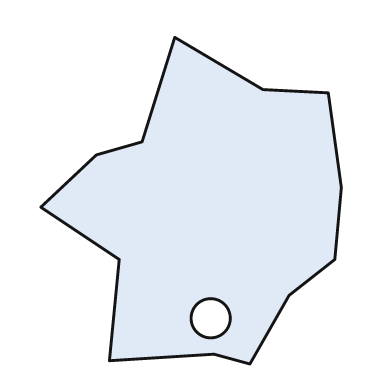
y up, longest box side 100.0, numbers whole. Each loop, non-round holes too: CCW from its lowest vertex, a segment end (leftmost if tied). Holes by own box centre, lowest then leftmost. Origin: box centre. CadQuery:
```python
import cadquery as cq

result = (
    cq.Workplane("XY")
    .moveTo(18.0, -50.0)
    .lineTo(30.0, -29.0)
    .lineTo(44.0, -18.0)
    .lineTo(46.0, 4.0)
    .lineTo(42.0, 33.0)
    .lineTo(22.0, 34.0)
    .lineTo(-5.0, 50.0)
    .lineTo(-15.0, 18.0)
    .lineTo(-29.0, 14.0)
    .lineTo(-46.0, -2.0)
    .lineTo(-22.0, -18.0)
    .lineTo(-25.0, -49.0)
    .lineTo(7.0, -47.0)
    .close()
    .moveTo(6.0, -36.0)
    .circle(6.0)
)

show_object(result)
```